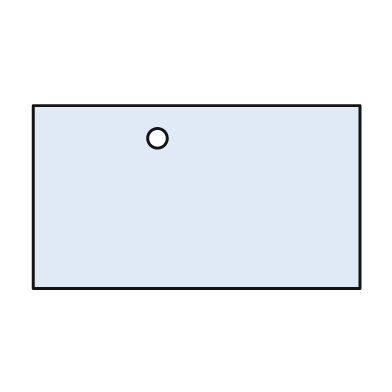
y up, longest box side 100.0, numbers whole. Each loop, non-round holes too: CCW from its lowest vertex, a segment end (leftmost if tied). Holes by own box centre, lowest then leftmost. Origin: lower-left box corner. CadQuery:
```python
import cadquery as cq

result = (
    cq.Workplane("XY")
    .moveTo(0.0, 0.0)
    .lineTo(100.0, 0.0)
    .lineTo(100.0, 56.0)
    .lineTo(0.0, 56.0)
    .close()
    .moveTo(38.0, 46.0)
    .circle(3.0)
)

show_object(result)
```